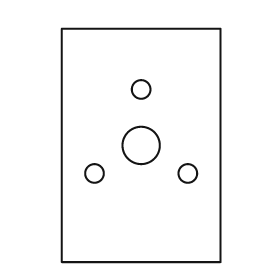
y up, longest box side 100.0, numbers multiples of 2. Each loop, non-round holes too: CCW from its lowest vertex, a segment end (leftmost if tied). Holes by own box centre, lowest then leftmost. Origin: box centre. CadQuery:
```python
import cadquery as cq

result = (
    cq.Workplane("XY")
    .moveTo(-34.0, -50.0)
    .lineTo(34.0, -50.0)
    .lineTo(34.0, 50.0)
    .lineTo(-34.0, 50.0)
    .close()
    .moveTo(-20.0, -12.0)
    .circle(4.0)
    .moveTo(20.0, -12.0)
    .circle(4.0)
    .moveTo(0.0, 0.0)
    .circle(8.0)
    .moveTo(0.0, 24.0)
    .circle(4.0)
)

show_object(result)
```